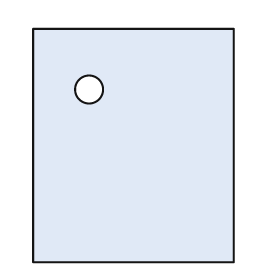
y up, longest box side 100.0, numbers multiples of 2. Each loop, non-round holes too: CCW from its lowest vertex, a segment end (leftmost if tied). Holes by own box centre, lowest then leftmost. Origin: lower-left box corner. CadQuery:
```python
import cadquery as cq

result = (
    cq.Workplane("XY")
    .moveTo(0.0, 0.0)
    .lineTo(86.0, 0.0)
    .lineTo(86.0, 100.0)
    .lineTo(0.0, 100.0)
    .close()
    .moveTo(24.0, 74.0)
    .circle(6.0)
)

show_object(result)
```